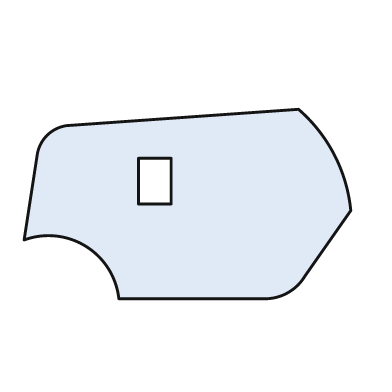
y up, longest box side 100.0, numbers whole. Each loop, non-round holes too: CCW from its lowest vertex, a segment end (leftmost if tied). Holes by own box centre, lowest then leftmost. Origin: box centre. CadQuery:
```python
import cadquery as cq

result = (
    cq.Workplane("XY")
    .moveTo(-21.0, -29.0)
    .lineTo(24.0, -29.0)
    .threePointArc((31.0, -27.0), (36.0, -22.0))
    .lineTo(50.0, -2.0)
    .threePointArc((45.0, 15.0), (34.0, 29.0))
    .lineTo(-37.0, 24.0)
    .threePointArc((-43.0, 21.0), (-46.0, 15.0))
    .lineTo(-50.0, -11.0)
    .threePointArc((-31.0, -13.0), (-21.0, -29.0))
    .close()
    .moveTo(-15.0, 0.0)
    .lineTo(-5.0, 0.0)
    .lineTo(-5.0, 14.0)
    .lineTo(-15.0, 14.0)
    .close()
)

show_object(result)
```